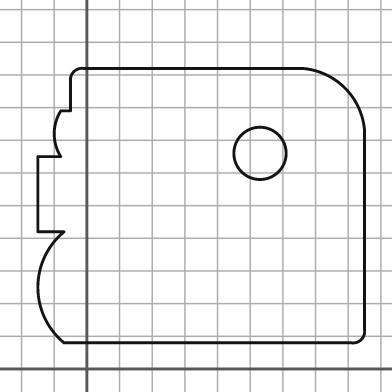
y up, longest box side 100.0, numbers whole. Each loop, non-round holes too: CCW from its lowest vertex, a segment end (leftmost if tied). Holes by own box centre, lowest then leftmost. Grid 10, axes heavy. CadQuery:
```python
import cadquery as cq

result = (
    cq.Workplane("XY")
    .moveTo(-7.0, 8.0)
    .lineTo(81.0, 8.0)
    .threePointArc((84.0, 9.0), (85.0, 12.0))
    .lineTo(85.0, 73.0)
    .threePointArc((79.0, 86.0), (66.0, 92.0))
    .lineTo(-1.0, 92.0)
    .threePointArc((-4.0, 91.0), (-5.0, 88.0))
    .lineTo(-5.0, 79.0)
    .lineTo(-8.0, 79.0)
    .threePointArc((-10.0, 72.0), (-8.0, 65.0))
    .lineTo(-15.0, 65.0)
    .lineTo(-15.0, 42.0)
    .lineTo(-7.0, 42.0)
    .threePointArc((-15.0, 25.0), (-7.0, 8.0))
    .close()
    .moveTo(53.0, 66.0)
    .circle(8.0)
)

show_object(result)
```